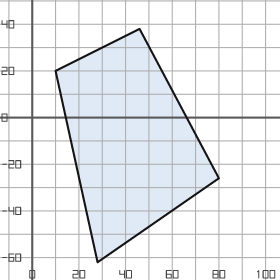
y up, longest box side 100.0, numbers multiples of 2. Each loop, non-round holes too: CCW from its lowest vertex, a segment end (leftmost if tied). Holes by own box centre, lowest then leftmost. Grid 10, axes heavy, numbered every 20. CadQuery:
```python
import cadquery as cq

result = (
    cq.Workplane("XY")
    .moveTo(28.0, -62.0)
    .lineTo(80.0, -26.0)
    .lineTo(46.0, 38.0)
    .lineTo(10.0, 20.0)
    .close()
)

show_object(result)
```